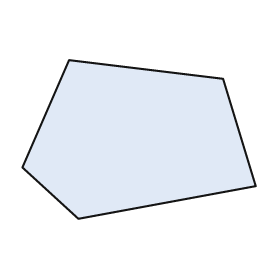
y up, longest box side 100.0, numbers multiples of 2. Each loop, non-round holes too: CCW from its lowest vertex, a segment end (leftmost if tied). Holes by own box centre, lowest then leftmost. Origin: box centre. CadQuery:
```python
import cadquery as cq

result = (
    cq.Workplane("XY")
    .moveTo(-26.0, -34.0)
    .lineTo(50.0, -20.0)
    .lineTo(36.0, 26.0)
    .lineTo(-30.0, 34.0)
    .lineTo(-50.0, -12.0)
    .close()
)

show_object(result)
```